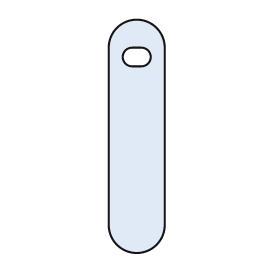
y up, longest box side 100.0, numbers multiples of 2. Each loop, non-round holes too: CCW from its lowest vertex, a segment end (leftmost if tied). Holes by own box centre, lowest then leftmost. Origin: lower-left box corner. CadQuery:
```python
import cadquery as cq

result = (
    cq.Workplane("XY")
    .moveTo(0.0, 12.0)
    .threePointArc((12.0, 0.0), (24.0, 12.0))
    .lineTo(24.0, 88.0)
    .threePointArc((12.0, 100.0), (0.0, 88.0))
    .close()
    .moveTo(10.0, 80.0)
    .lineTo(14.0, 80.0)
    .threePointArc((18.0, 84.0), (14.0, 88.0))
    .lineTo(10.0, 88.0)
    .threePointArc((6.0, 84.0), (10.0, 80.0))
    .close()
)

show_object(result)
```